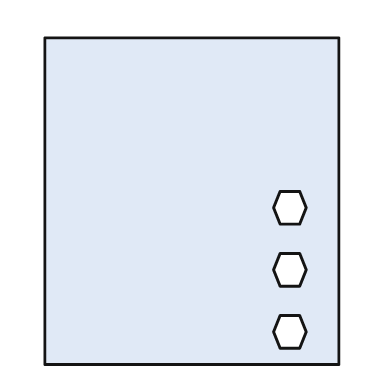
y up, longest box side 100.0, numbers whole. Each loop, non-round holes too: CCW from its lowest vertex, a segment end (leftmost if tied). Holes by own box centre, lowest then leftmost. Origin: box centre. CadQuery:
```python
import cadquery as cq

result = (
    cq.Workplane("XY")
    .moveTo(-45.0, -50.0)
    .lineTo(45.0, -50.0)
    .lineTo(45.0, 50.0)
    .lineTo(-45.0, 50.0)
    .close()
    .moveTo(27.0, -45.0)
    .lineTo(33.0, -45.0)
    .lineTo(35.0, -40.0)
    .lineTo(33.0, -35.0)
    .lineTo(27.0, -35.0)
    .lineTo(25.0, -40.0)
    .close()
    .moveTo(27.0, -26.0)
    .lineTo(33.0, -26.0)
    .lineTo(35.0, -21.0)
    .lineTo(33.0, -16.0)
    .lineTo(27.0, -16.0)
    .lineTo(25.0, -21.0)
    .close()
    .moveTo(27.0, -7.0)
    .lineTo(33.0, -7.0)
    .lineTo(35.0, -2.0)
    .lineTo(33.0, 3.0)
    .lineTo(27.0, 3.0)
    .lineTo(25.0, -2.0)
    .close()
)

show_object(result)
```